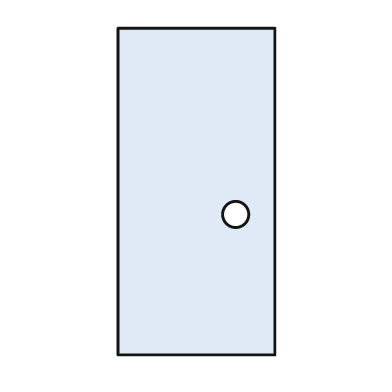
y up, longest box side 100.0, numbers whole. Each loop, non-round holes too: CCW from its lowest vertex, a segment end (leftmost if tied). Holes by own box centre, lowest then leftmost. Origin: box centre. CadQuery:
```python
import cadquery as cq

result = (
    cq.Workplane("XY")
    .moveTo(-24.0, -50.0)
    .lineTo(24.0, -50.0)
    .lineTo(24.0, 50.0)
    .lineTo(-24.0, 50.0)
    .close()
    .moveTo(12.0, -7.0)
    .circle(4.0)
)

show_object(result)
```